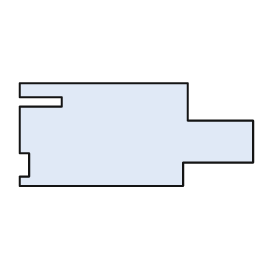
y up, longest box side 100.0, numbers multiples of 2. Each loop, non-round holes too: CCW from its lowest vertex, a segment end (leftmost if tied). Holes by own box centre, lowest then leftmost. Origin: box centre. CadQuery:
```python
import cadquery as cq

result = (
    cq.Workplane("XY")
    .moveTo(-50.0, -22.0)
    .lineTo(20.0, -22.0)
    .lineTo(20.0, -12.0)
    .lineTo(50.0, -12.0)
    .lineTo(50.0, 6.0)
    .lineTo(22.0, 6.0)
    .lineTo(22.0, 22.0)
    .lineTo(-50.0, 22.0)
    .lineTo(-50.0, 16.0)
    .lineTo(-32.0, 16.0)
    .lineTo(-32.0, 12.0)
    .lineTo(-50.0, 12.0)
    .lineTo(-50.0, -8.0)
    .lineTo(-46.0, -8.0)
    .lineTo(-46.0, -18.0)
    .lineTo(-50.0, -18.0)
    .close()
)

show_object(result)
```